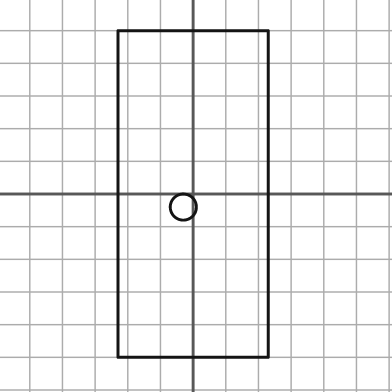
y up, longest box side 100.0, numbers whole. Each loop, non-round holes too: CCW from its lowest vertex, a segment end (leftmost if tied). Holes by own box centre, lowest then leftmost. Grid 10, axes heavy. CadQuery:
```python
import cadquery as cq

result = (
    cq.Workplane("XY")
    .moveTo(-23.0, -50.0)
    .lineTo(23.0, -50.0)
    .lineTo(23.0, 50.0)
    .lineTo(-23.0, 50.0)
    .close()
    .moveTo(-3.0, -4.0)
    .circle(4.0)
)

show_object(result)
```